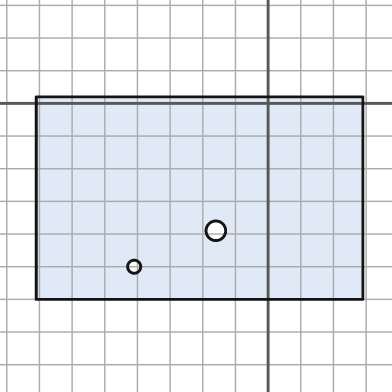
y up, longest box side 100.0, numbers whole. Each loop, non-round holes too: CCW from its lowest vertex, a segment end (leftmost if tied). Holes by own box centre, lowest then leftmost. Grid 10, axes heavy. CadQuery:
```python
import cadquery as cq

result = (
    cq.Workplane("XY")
    .moveTo(-71.0, -60.0)
    .lineTo(29.0, -60.0)
    .lineTo(29.0, 2.0)
    .lineTo(-71.0, 2.0)
    .close()
    .moveTo(-41.0, -50.0)
    .circle(2.0)
    .moveTo(-16.0, -39.0)
    .circle(3.0)
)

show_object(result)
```